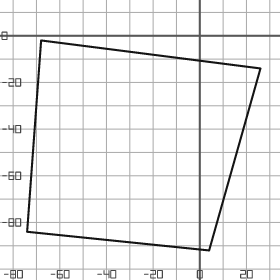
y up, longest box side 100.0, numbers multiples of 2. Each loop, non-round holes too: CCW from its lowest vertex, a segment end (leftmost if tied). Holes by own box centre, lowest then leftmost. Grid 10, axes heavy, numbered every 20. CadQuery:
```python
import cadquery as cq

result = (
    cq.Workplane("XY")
    .moveTo(4.0, -92.0)
    .lineTo(26.0, -14.0)
    .lineTo(-68.0, -2.0)
    .lineTo(-74.0, -84.0)
    .close()
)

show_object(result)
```